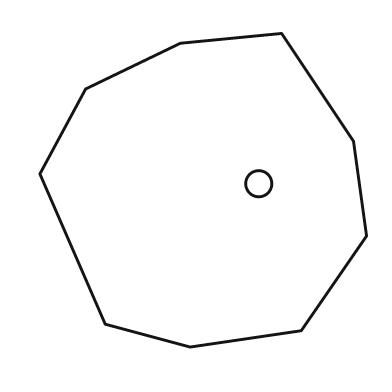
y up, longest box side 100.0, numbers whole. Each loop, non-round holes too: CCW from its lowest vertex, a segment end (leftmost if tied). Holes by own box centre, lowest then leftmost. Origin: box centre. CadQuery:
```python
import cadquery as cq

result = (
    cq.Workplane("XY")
    .moveTo(-4.0, -48.0)
    .lineTo(30.0, -43.0)
    .lineTo(50.0, -14.0)
    .lineTo(46.0, 15.0)
    .lineTo(24.0, 48.0)
    .lineTo(-7.0, 45.0)
    .lineTo(-36.0, 31.0)
    .lineTo(-50.0, 5.0)
    .lineTo(-30.0, -41.0)
    .close()
    .moveTo(17.0, 2.0)
    .circle(4.0)
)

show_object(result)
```